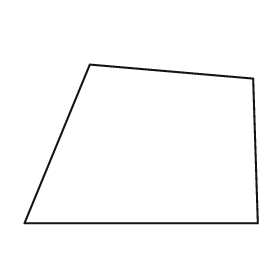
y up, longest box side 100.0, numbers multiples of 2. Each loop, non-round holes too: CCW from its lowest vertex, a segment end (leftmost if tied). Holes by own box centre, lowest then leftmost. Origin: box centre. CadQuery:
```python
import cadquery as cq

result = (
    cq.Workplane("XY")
    .moveTo(-50.0, -34.0)
    .lineTo(50.0, -34.0)
    .lineTo(48.0, 28.0)
    .lineTo(-22.0, 34.0)
    .close()
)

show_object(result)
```